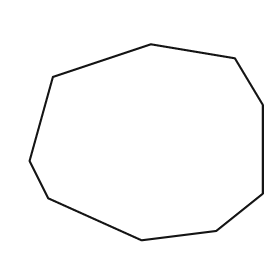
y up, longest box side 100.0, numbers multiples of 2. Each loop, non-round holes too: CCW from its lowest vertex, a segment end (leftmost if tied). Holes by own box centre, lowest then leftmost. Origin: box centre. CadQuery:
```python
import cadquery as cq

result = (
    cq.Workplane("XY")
    .moveTo(-2.0, -42.0)
    .lineTo(30.0, -38.0)
    .lineTo(50.0, -22.0)
    .lineTo(50.0, 16.0)
    .lineTo(38.0, 36.0)
    .lineTo(2.0, 42.0)
    .lineTo(-40.0, 28.0)
    .lineTo(-50.0, -8.0)
    .lineTo(-42.0, -24.0)
    .close()
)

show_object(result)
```